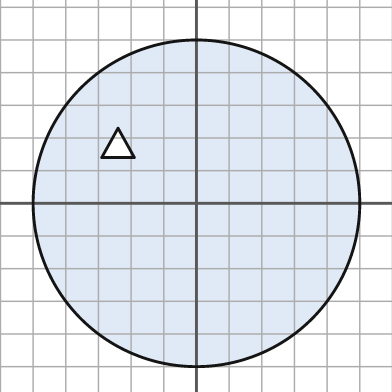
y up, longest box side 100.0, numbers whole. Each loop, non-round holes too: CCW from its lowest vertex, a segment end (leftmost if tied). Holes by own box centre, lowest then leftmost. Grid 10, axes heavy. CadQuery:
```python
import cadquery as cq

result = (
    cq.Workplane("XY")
    .moveTo(0.0, 0.0)
    .circle(50.0)
    .moveTo(-29.0, 14.0)
    .lineTo(-19.0, 14.0)
    .lineTo(-24.0, 23.0)
    .close()
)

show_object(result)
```